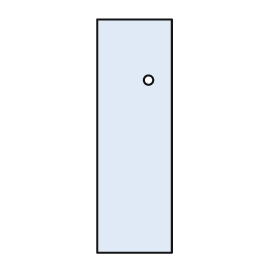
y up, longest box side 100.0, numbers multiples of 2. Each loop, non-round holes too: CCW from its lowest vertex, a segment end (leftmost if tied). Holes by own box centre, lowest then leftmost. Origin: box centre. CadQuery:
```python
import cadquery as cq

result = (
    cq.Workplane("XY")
    .moveTo(-16.0, -50.0)
    .lineTo(16.0, -50.0)
    .lineTo(16.0, 50.0)
    .lineTo(-16.0, 50.0)
    .close()
    .moveTo(6.0, 24.0)
    .circle(2.0)
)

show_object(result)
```